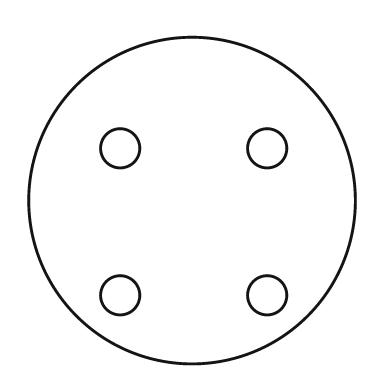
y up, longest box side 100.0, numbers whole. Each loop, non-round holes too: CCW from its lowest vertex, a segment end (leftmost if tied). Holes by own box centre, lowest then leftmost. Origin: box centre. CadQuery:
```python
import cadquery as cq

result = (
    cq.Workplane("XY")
    .moveTo(0.0, 0.0)
    .circle(50.0)
    .moveTo(-22.0, -29.0)
    .circle(6.0)
    .moveTo(23.0, -29.0)
    .circle(6.0)
    .moveTo(-22.0, 16.0)
    .circle(6.0)
    .moveTo(23.0, 16.0)
    .circle(6.0)
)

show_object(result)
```